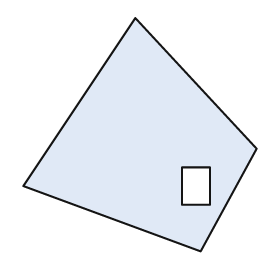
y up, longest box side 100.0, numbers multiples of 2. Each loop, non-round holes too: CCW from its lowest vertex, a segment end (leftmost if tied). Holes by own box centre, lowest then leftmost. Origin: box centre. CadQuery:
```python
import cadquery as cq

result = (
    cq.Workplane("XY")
    .moveTo(26.0, -50.0)
    .lineTo(50.0, -6.0)
    .lineTo(-2.0, 50.0)
    .lineTo(-50.0, -22.0)
    .close()
    .moveTo(18.0, -30.0)
    .lineTo(30.0, -30.0)
    .lineTo(30.0, -14.0)
    .lineTo(18.0, -14.0)
    .close()
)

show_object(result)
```